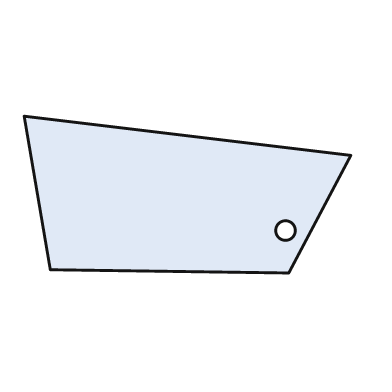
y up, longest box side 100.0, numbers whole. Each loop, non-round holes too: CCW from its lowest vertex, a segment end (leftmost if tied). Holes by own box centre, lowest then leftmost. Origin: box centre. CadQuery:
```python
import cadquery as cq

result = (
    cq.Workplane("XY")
    .moveTo(31.0, -24.0)
    .lineTo(50.0, 12.0)
    .lineTo(-50.0, 24.0)
    .lineTo(-42.0, -23.0)
    .close()
    .moveTo(30.0, -11.0)
    .circle(3.0)
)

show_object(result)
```